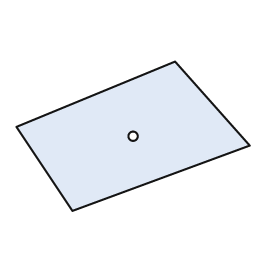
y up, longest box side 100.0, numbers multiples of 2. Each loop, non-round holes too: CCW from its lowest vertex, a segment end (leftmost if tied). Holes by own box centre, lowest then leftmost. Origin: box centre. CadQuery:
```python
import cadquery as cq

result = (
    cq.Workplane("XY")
    .moveTo(-26.0, -32.0)
    .lineTo(50.0, -4.0)
    .lineTo(18.0, 32.0)
    .lineTo(-50.0, 4.0)
    .close()
    .moveTo(0.0, 0.0)
    .circle(2.0)
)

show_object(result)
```